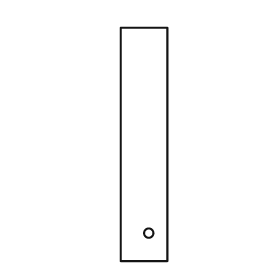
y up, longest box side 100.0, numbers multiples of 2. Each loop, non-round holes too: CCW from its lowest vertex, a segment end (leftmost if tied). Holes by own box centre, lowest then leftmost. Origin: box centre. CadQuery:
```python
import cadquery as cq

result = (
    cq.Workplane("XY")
    .moveTo(-10.0, -50.0)
    .lineTo(10.0, -50.0)
    .lineTo(10.0, 50.0)
    .lineTo(-10.0, 50.0)
    .close()
    .moveTo(2.0, -38.0)
    .circle(2.0)
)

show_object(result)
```